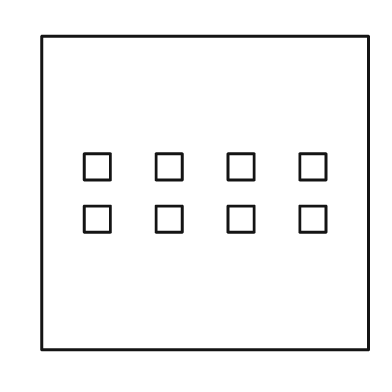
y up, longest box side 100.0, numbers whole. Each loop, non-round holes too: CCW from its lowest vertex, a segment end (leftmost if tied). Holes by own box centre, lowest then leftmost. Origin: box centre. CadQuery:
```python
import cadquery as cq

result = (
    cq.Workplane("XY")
    .moveTo(-50.0, -48.0)
    .lineTo(50.0, -48.0)
    .lineTo(50.0, 48.0)
    .lineTo(-50.0, 48.0)
    .close()
    .moveTo(-37.0, -12.0)
    .lineTo(-29.0, -12.0)
    .lineTo(-29.0, -4.0)
    .lineTo(-37.0, -4.0)
    .close()
    .moveTo(-15.0, -12.0)
    .lineTo(-7.0, -12.0)
    .lineTo(-7.0, -4.0)
    .lineTo(-15.0, -4.0)
    .close()
    .moveTo(7.0, -12.0)
    .lineTo(15.0, -12.0)
    .lineTo(15.0, -4.0)
    .lineTo(7.0, -4.0)
    .close()
    .moveTo(29.0, -12.0)
    .lineTo(37.0, -12.0)
    .lineTo(37.0, -4.0)
    .lineTo(29.0, -4.0)
    .close()
    .moveTo(-37.0, 4.0)
    .lineTo(-29.0, 4.0)
    .lineTo(-29.0, 12.0)
    .lineTo(-37.0, 12.0)
    .close()
    .moveTo(-15.0, 4.0)
    .lineTo(-7.0, 4.0)
    .lineTo(-7.0, 12.0)
    .lineTo(-15.0, 12.0)
    .close()
    .moveTo(7.0, 4.0)
    .lineTo(15.0, 4.0)
    .lineTo(15.0, 12.0)
    .lineTo(7.0, 12.0)
    .close()
    .moveTo(29.0, 4.0)
    .lineTo(37.0, 4.0)
    .lineTo(37.0, 12.0)
    .lineTo(29.0, 12.0)
    .close()
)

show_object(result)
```